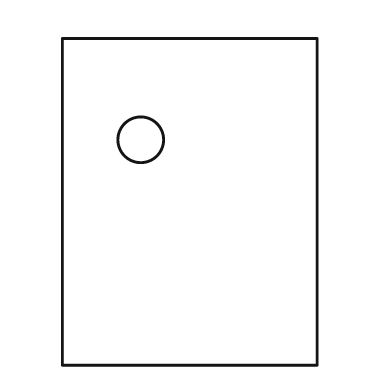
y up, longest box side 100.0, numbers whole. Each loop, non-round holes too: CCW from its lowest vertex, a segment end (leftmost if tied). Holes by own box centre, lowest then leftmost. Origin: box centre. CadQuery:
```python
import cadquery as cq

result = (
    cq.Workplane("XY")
    .moveTo(-39.0, -50.0)
    .lineTo(39.0, -50.0)
    .lineTo(39.0, 50.0)
    .lineTo(-39.0, 50.0)
    .close()
    .moveTo(-15.0, 19.0)
    .circle(7.0)
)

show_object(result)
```